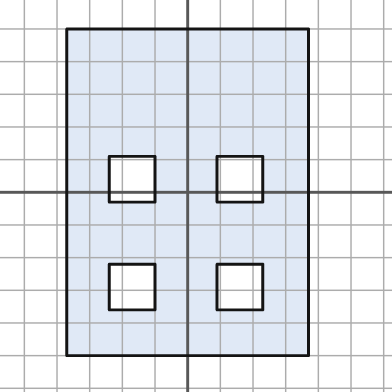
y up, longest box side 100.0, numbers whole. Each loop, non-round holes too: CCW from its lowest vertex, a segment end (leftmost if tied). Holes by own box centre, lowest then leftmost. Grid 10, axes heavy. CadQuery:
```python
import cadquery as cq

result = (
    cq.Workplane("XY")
    .moveTo(-37.0, -50.0)
    .lineTo(37.0, -50.0)
    .lineTo(37.0, 50.0)
    .lineTo(-37.0, 50.0)
    .close()
    .moveTo(-24.0, -36.0)
    .lineTo(-10.0, -36.0)
    .lineTo(-10.0, -22.0)
    .lineTo(-24.0, -22.0)
    .close()
    .moveTo(9.0, -36.0)
    .lineTo(23.0, -36.0)
    .lineTo(23.0, -22.0)
    .lineTo(9.0, -22.0)
    .close()
    .moveTo(-24.0, -3.0)
    .lineTo(-10.0, -3.0)
    .lineTo(-10.0, 11.0)
    .lineTo(-24.0, 11.0)
    .close()
    .moveTo(9.0, -3.0)
    .lineTo(23.0, -3.0)
    .lineTo(23.0, 11.0)
    .lineTo(9.0, 11.0)
    .close()
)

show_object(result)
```